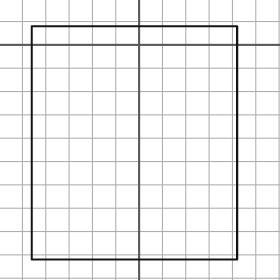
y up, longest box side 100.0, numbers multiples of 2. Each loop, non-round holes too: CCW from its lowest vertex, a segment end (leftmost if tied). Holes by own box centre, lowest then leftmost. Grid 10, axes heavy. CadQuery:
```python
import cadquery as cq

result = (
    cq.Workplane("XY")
    .moveTo(-46.0, -92.0)
    .lineTo(42.0, -92.0)
    .lineTo(42.0, 8.0)
    .lineTo(-46.0, 8.0)
    .close()
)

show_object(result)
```